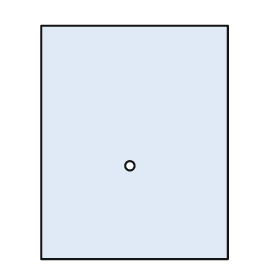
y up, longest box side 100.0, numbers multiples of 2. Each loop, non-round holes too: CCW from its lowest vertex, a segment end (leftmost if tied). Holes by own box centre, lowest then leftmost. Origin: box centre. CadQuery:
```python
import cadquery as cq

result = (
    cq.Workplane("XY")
    .moveTo(-40.0, -50.0)
    .lineTo(40.0, -50.0)
    .lineTo(40.0, 50.0)
    .lineTo(-40.0, 50.0)
    .close()
    .moveTo(-2.0, -10.0)
    .circle(2.0)
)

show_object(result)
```